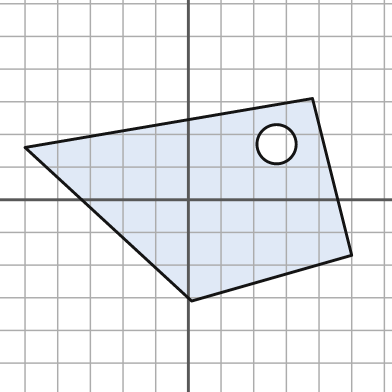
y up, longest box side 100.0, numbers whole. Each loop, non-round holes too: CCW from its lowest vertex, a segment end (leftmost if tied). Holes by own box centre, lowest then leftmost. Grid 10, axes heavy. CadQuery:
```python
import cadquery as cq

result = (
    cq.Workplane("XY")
    .moveTo(1.0, -31.0)
    .lineTo(50.0, -17.0)
    .lineTo(38.0, 31.0)
    .lineTo(-50.0, 16.0)
    .close()
    .moveTo(27.0, 17.0)
    .circle(6.0)
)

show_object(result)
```